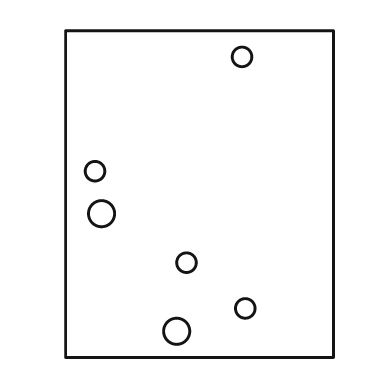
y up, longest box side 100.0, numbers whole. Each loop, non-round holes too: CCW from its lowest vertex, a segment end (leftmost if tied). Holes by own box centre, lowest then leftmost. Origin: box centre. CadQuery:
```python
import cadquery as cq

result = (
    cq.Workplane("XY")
    .moveTo(-41.0, -50.0)
    .lineTo(41.0, -50.0)
    .lineTo(41.0, 50.0)
    .lineTo(-41.0, 50.0)
    .close()
    .moveTo(-7.0, -42.0)
    .circle(4.0)
    .moveTo(14.0, -35.0)
    .circle(3.0)
    .moveTo(-4.0, -21.0)
    .circle(3.0)
    .moveTo(-30.0, -6.0)
    .circle(4.0)
    .moveTo(-32.0, 7.0)
    .circle(3.0)
    .moveTo(13.0, 42.0)
    .circle(3.0)
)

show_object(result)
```